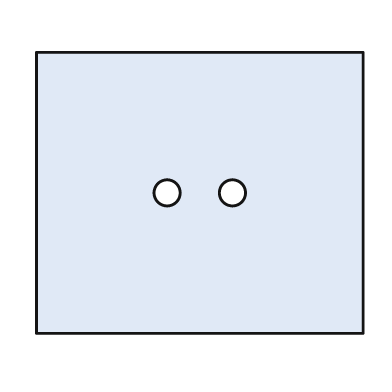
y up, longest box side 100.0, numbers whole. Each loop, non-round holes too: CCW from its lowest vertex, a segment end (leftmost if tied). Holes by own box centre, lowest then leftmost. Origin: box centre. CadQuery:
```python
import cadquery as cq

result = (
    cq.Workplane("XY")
    .moveTo(-50.0, -43.0)
    .lineTo(50.0, -43.0)
    .lineTo(50.0, 43.0)
    .lineTo(-50.0, 43.0)
    .close()
    .moveTo(-10.0, 0.0)
    .circle(4.0)
    .moveTo(10.0, 0.0)
    .circle(4.0)
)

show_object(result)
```